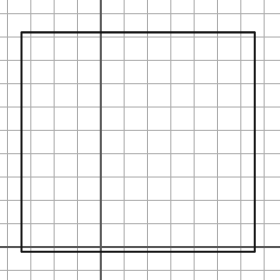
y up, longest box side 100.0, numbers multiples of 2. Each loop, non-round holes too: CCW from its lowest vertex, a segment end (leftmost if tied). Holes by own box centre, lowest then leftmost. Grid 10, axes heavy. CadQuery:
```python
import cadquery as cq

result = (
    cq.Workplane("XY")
    .moveTo(-34.0, -2.0)
    .lineTo(66.0, -2.0)
    .lineTo(66.0, 92.0)
    .lineTo(-34.0, 92.0)
    .close()
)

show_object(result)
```